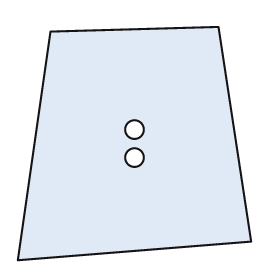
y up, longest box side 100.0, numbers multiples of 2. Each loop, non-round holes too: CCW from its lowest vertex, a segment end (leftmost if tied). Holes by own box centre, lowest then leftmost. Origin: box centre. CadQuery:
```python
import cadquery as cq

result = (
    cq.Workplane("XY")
    .moveTo(-50.0, -50.0)
    .lineTo(50.0, -42.0)
    .lineTo(36.0, 50.0)
    .lineTo(-36.0, 48.0)
    .close()
    .moveTo(0.0, -6.0)
    .circle(4.0)
    .moveTo(0.0, 6.0)
    .circle(4.0)
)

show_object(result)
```